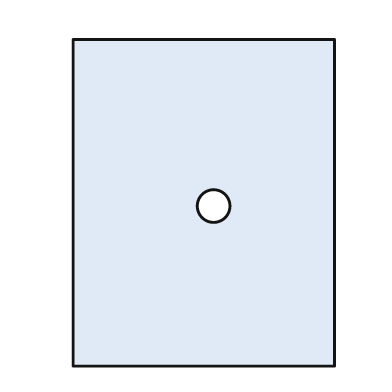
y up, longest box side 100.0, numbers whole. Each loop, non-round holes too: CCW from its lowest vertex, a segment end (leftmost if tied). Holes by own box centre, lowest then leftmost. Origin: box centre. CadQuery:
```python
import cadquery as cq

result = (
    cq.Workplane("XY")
    .moveTo(-40.0, -50.0)
    .lineTo(40.0, -50.0)
    .lineTo(40.0, 50.0)
    .lineTo(-40.0, 50.0)
    .close()
    .moveTo(3.0, -1.0)
    .circle(5.0)
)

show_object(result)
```